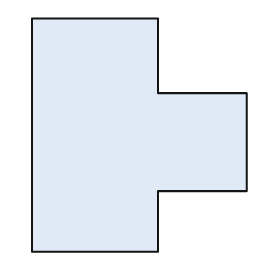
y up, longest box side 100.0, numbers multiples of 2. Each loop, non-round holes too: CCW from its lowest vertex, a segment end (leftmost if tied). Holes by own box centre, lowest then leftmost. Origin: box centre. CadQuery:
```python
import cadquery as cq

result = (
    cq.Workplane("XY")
    .moveTo(-46.0, -50.0)
    .lineTo(8.0, -50.0)
    .lineTo(8.0, -24.0)
    .lineTo(46.0, -24.0)
    .lineTo(46.0, 18.0)
    .lineTo(8.0, 18.0)
    .lineTo(8.0, 50.0)
    .lineTo(-46.0, 50.0)
    .close()
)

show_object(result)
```